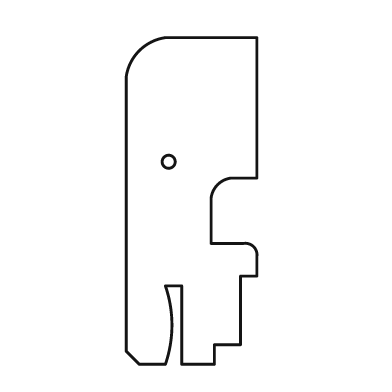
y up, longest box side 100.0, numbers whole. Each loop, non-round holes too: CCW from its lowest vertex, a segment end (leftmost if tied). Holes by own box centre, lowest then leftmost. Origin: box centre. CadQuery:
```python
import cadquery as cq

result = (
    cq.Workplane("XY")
    .moveTo(-16.0, -50.0)
    .lineTo(-8.0, -50.0)
    .threePointArc((-6.0, -38.0), (-8.0, -26.0))
    .lineTo(-3.0, -26.0)
    .lineTo(-3.0, -50.0)
    .lineTo(7.0, -50.0)
    .lineTo(7.0, -44.0)
    .lineTo(15.0, -44.0)
    .lineTo(15.0, -23.0)
    .lineTo(20.0, -23.0)
    .lineTo(20.0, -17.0)
    .threePointArc((19.0, -14.0), (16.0, -13.0))
    .lineTo(6.0, -13.0)
    .lineTo(6.0, 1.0)
    .threePointArc((8.0, 5.0), (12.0, 7.0))
    .lineTo(20.0, 7.0)
    .lineTo(20.0, 50.0)
    .lineTo(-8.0, 50.0)
    .threePointArc((-16.0, 46.0), (-20.0, 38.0))
    .lineTo(-20.0, -46.0)
    .close()
    .moveTo(-7.0, 12.0)
    .circle(2.0)
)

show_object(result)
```